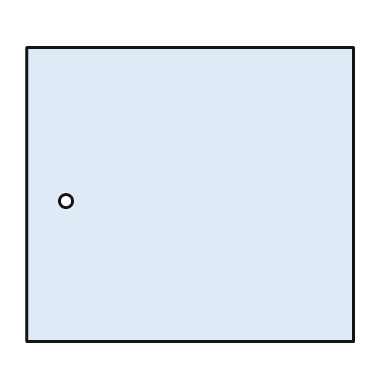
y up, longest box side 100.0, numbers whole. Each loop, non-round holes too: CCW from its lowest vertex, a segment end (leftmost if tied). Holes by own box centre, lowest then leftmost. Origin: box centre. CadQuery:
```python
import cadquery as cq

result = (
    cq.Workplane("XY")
    .moveTo(-50.0, -45.0)
    .lineTo(50.0, -45.0)
    .lineTo(50.0, 45.0)
    .lineTo(-50.0, 45.0)
    .close()
    .moveTo(-38.0, -2.0)
    .circle(2.0)
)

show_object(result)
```